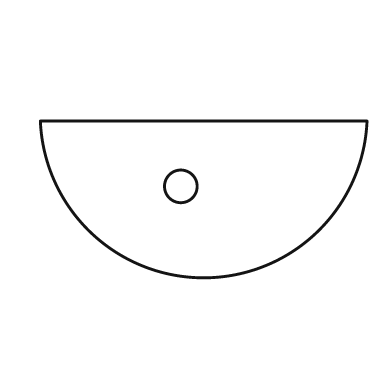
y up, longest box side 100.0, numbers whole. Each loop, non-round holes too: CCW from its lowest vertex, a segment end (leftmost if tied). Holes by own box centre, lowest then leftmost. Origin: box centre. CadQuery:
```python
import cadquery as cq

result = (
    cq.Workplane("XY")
    .moveTo(-50.0, 24.0)
    .threePointArc((0.0, -24.0), (50.0, 24.0))
    .close()
    .moveTo(-7.0, 4.0)
    .circle(5.0)
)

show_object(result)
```